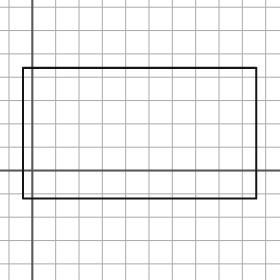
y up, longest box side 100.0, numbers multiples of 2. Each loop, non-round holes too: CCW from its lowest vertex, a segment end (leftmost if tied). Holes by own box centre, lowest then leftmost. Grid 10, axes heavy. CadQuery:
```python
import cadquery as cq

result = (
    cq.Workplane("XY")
    .moveTo(-4.0, -12.0)
    .lineTo(96.0, -12.0)
    .lineTo(96.0, 44.0)
    .lineTo(-4.0, 44.0)
    .close()
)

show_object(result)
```